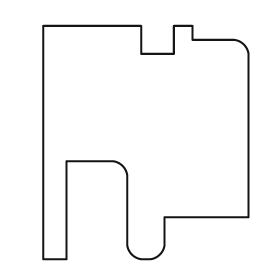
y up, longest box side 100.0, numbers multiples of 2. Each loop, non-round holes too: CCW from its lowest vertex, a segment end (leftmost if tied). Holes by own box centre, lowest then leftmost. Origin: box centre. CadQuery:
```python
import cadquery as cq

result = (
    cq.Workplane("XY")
    .moveTo(-44.0, -50.0)
    .lineTo(-34.0, -50.0)
    .lineTo(-34.0, -8.0)
    .lineTo(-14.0, -8.0)
    .threePointArc((-10.0, -10.0), (-8.0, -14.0))
    .lineTo(-8.0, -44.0)
    .threePointArc((-6.0, -48.0), (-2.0, -50.0))
    .lineTo(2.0, -50.0)
    .threePointArc((6.0, -48.0), (8.0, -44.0))
    .lineTo(8.0, -32.0)
    .lineTo(44.0, -32.0)
    .lineTo(44.0, 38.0)
    .threePointArc((42.0, 42.0), (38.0, 44.0))
    .lineTo(20.0, 44.0)
    .lineTo(20.0, 50.0)
    .lineTo(12.0, 50.0)
    .lineTo(12.0, 38.0)
    .lineTo(-2.0, 38.0)
    .lineTo(-2.0, 50.0)
    .lineTo(-44.0, 50.0)
    .close()
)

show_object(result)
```